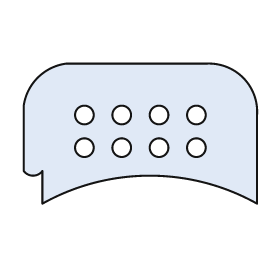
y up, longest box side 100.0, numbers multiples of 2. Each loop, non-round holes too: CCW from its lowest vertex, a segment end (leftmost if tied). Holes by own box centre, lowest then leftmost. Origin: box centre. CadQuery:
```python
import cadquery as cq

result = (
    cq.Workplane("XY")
    .moveTo(-42.0, -30.0)
    .threePointArc((4.0, -18.0), (50.0, -30.0))
    .lineTo(50.0, 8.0)
    .threePointArc((44.0, 24.0), (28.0, 30.0))
    .lineTo(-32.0, 30.0)
    .threePointArc((-44.0, 24.0), (-50.0, 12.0))
    .lineTo(-50.0, -16.0)
    .threePointArc((-46.0, -18.0), (-42.0, -16.0))
    .close()
    .moveTo(-24.0, -6.0)
    .circle(4.0)
    .moveTo(-8.0, -6.0)
    .circle(4.0)
    .moveTo(8.0, -6.0)
    .circle(4.0)
    .moveTo(24.0, -6.0)
    .circle(4.0)
    .moveTo(-24.0, 8.0)
    .circle(4.0)
    .moveTo(-8.0, 8.0)
    .circle(4.0)
    .moveTo(8.0, 8.0)
    .circle(4.0)
    .moveTo(24.0, 8.0)
    .circle(4.0)
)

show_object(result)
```